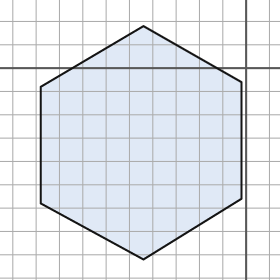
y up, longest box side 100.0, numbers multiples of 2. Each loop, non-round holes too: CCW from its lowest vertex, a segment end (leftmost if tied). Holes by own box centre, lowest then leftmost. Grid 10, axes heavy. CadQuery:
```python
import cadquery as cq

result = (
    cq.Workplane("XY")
    .moveTo(-44.0, -82.0)
    .lineTo(-2.0, -56.0)
    .lineTo(-2.0, -6.0)
    .lineTo(-44.0, 18.0)
    .lineTo(-88.0, -8.0)
    .lineTo(-88.0, -58.0)
    .close()
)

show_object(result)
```